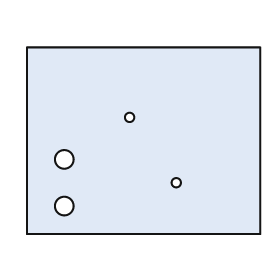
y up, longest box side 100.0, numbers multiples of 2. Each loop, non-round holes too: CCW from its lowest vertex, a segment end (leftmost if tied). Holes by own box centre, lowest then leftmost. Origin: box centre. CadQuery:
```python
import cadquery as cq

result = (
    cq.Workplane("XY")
    .moveTo(-50.0, -40.0)
    .lineTo(50.0, -40.0)
    .lineTo(50.0, 40.0)
    .lineTo(-50.0, 40.0)
    .close()
    .moveTo(-34.0, -28.0)
    .circle(4.0)
    .moveTo(14.0, -18.0)
    .circle(2.0)
    .moveTo(-34.0, -8.0)
    .circle(4.0)
    .moveTo(-6.0, 10.0)
    .circle(2.0)
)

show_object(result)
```